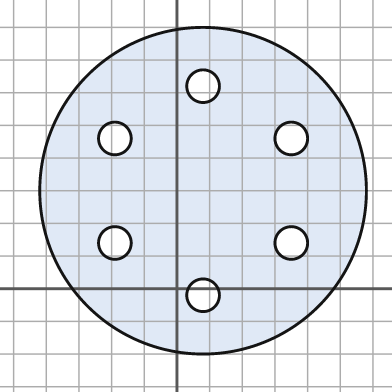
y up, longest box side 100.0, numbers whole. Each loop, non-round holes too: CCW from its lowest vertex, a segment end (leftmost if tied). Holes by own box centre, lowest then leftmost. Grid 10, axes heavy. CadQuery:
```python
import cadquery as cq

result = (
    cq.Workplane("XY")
    .moveTo(8.0, 30.0)
    .circle(50.0)
    .moveTo(8.0, -2.0)
    .circle(5.0)
    .moveTo(-19.0, 14.0)
    .circle(5.0)
    .moveTo(35.0, 14.0)
    .circle(5.0)
    .moveTo(-19.0, 46.0)
    .circle(5.0)
    .moveTo(35.0, 46.0)
    .circle(5.0)
    .moveTo(8.0, 62.0)
    .circle(5.0)
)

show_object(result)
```